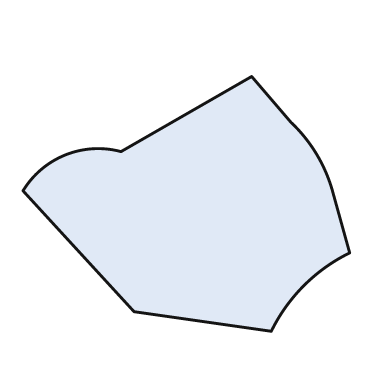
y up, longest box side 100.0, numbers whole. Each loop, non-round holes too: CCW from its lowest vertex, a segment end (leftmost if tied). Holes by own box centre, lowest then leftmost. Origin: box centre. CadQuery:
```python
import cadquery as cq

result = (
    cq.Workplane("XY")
    .moveTo(26.0, -39.0)
    .threePointArc((36.0, -25.0), (50.0, -15.0))
    .lineTo(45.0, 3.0)
    .threePointArc((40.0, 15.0), (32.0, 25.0))
    .lineTo(20.0, 39.0)
    .lineTo(-20.0, 16.0)
    .threePointArc((-37.0, 15.0), (-50.0, 4.0))
    .lineTo(-16.0, -33.0)
    .close()
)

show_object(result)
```